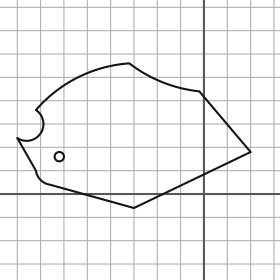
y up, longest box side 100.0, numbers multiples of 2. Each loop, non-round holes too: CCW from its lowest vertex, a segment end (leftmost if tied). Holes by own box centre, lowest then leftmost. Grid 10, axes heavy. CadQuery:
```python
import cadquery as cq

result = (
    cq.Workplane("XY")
    .moveTo(-30.0, -6.0)
    .lineTo(20.0, 18.0)
    .lineTo(-2.0, 44.0)
    .threePointArc((-18.0, 48.0), (-32.0, 56.0))
    .threePointArc((-54.0, 50.0), (-72.0, 36.0))
    .threePointArc((-70.0, 26.0), (-80.0, 24.0))
    .lineTo(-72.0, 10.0)
    .threePointArc((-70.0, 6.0), (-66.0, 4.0))
    .close()
    .moveTo(-62.0, 16.0)
    .circle(2.0)
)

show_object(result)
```